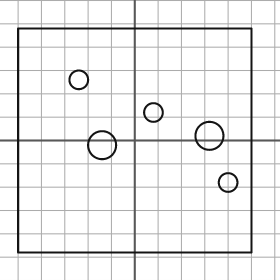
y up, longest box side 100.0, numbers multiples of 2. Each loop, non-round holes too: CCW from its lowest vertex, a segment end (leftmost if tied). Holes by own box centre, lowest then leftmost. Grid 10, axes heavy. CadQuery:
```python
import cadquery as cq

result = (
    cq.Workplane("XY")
    .moveTo(-50.0, -48.0)
    .lineTo(50.0, -48.0)
    .lineTo(50.0, 48.0)
    .lineTo(-50.0, 48.0)
    .close()
    .moveTo(40.0, -18.0)
    .circle(4.0)
    .moveTo(-14.0, -2.0)
    .circle(6.0)
    .moveTo(32.0, 2.0)
    .circle(6.0)
    .moveTo(8.0, 12.0)
    .circle(4.0)
    .moveTo(-24.0, 26.0)
    .circle(4.0)
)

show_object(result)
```